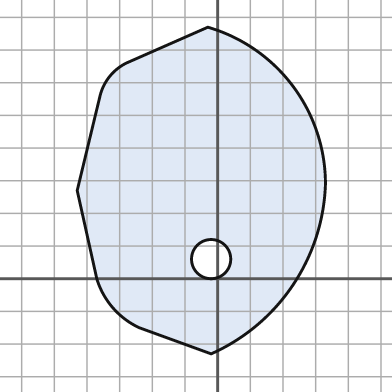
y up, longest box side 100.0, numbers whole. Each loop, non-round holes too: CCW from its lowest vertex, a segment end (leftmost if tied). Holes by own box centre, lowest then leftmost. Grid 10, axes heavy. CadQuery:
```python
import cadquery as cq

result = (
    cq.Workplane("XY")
    .moveTo(-2.0, -23.0)
    .threePointArc((23.0, -2.0), (33.0, 29.0))
    .threePointArc((23.0, 59.0), (-3.0, 77.0))
    .lineTo(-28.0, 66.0)
    .threePointArc((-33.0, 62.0), (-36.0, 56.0))
    .lineTo(-43.0, 27.0)
    .lineTo(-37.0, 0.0)
    .threePointArc((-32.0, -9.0), (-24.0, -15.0))
    .close()
    .moveTo(-2.0, 6.0)
    .circle(6.0)
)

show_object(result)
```